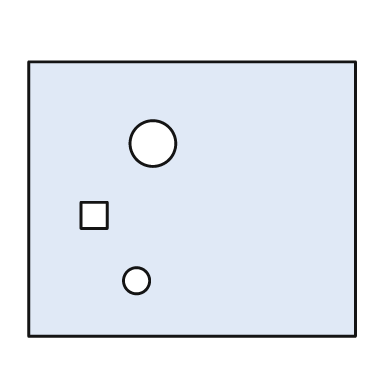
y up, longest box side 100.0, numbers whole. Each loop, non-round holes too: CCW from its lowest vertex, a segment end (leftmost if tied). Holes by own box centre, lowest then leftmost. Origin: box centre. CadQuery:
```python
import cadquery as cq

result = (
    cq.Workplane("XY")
    .moveTo(-50.0, -42.0)
    .lineTo(50.0, -42.0)
    .lineTo(50.0, 42.0)
    .lineTo(-50.0, 42.0)
    .close()
    .moveTo(-17.0, -25.0)
    .circle(4.0)
    .moveTo(-34.0, -9.0)
    .lineTo(-26.0, -9.0)
    .lineTo(-26.0, -1.0)
    .lineTo(-34.0, -1.0)
    .close()
    .moveTo(-12.0, 17.0)
    .circle(7.0)
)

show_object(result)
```